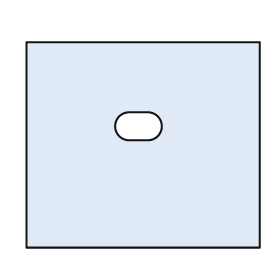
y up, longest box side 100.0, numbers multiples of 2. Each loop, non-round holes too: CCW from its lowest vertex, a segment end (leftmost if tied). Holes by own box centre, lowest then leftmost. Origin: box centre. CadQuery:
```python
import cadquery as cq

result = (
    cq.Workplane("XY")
    .moveTo(-50.0, -44.0)
    .lineTo(50.0, -44.0)
    .lineTo(50.0, 44.0)
    .lineTo(-50.0, 44.0)
    .close()
    .moveTo(-6.0, 2.0)
    .lineTo(2.0, 2.0)
    .threePointArc((8.0, 8.0), (2.0, 14.0))
    .lineTo(-6.0, 14.0)
    .threePointArc((-12.0, 8.0), (-6.0, 2.0))
    .close()
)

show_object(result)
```